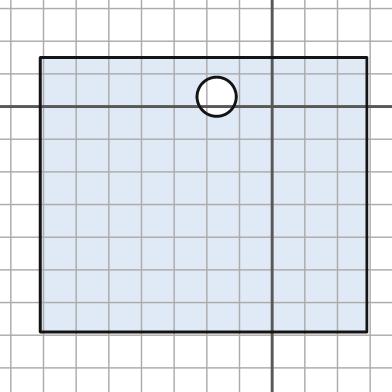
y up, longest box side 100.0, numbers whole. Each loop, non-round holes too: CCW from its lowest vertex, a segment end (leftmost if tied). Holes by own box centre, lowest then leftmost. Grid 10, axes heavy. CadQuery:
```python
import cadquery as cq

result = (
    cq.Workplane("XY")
    .moveTo(-71.0, -69.0)
    .lineTo(29.0, -69.0)
    .lineTo(29.0, 15.0)
    .lineTo(-71.0, 15.0)
    .close()
    .moveTo(-17.0, 3.0)
    .circle(6.0)
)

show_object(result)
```